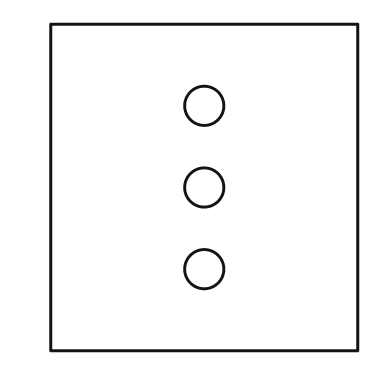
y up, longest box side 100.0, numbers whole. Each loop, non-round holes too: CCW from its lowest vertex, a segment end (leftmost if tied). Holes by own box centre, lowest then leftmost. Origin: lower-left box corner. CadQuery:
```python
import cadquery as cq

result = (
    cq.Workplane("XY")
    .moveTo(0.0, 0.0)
    .lineTo(94.0, 0.0)
    .lineTo(94.0, 100.0)
    .lineTo(0.0, 100.0)
    .close()
    .moveTo(47.0, 25.0)
    .circle(6.0)
    .moveTo(47.0, 50.0)
    .circle(6.0)
    .moveTo(47.0, 75.0)
    .circle(6.0)
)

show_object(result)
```